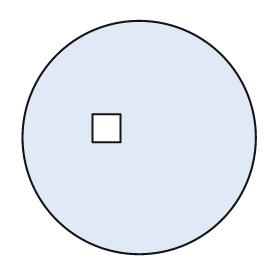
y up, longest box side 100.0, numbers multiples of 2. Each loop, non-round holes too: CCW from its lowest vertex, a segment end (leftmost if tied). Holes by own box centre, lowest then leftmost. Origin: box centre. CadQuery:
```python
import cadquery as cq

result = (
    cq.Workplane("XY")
    .moveTo(0.0, 0.0)
    .circle(50.0)
    .moveTo(-20.0, -2.0)
    .lineTo(-8.0, -2.0)
    .lineTo(-8.0, 10.0)
    .lineTo(-20.0, 10.0)
    .close()
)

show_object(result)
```